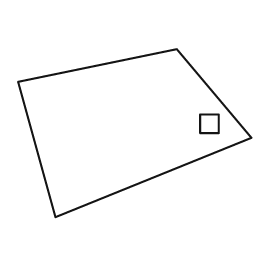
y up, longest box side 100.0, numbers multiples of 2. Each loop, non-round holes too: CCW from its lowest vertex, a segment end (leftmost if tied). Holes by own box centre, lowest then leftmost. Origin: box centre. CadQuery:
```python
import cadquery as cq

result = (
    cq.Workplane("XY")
    .moveTo(-34.0, -36.0)
    .lineTo(50.0, -2.0)
    .lineTo(18.0, 36.0)
    .lineTo(-50.0, 22.0)
    .close()
    .moveTo(28.0, 0.0)
    .lineTo(36.0, 0.0)
    .lineTo(36.0, 8.0)
    .lineTo(28.0, 8.0)
    .close()
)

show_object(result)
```